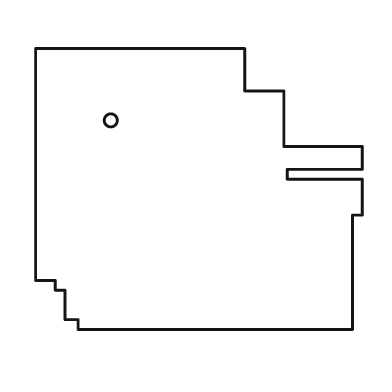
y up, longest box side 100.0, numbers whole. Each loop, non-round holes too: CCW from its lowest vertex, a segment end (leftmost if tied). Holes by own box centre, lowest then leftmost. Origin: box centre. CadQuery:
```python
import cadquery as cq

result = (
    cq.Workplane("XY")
    .moveTo(-37.0, -43.0)
    .lineTo(47.0, -43.0)
    .lineTo(47.0, -8.0)
    .lineTo(50.0, -8.0)
    .lineTo(50.0, 3.0)
    .lineTo(27.0, 3.0)
    .lineTo(27.0, 6.0)
    .lineTo(50.0, 6.0)
    .lineTo(50.0, 13.0)
    .lineTo(26.0, 13.0)
    .lineTo(26.0, 30.0)
    .lineTo(14.0, 30.0)
    .lineTo(14.0, 43.0)
    .lineTo(-50.0, 43.0)
    .lineTo(-50.0, -28.0)
    .lineTo(-44.0, -28.0)
    .lineTo(-44.0, -31.0)
    .lineTo(-41.0, -31.0)
    .lineTo(-41.0, -40.0)
    .lineTo(-37.0, -40.0)
    .close()
    .moveTo(-27.0, 21.0)
    .circle(2.0)
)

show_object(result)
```